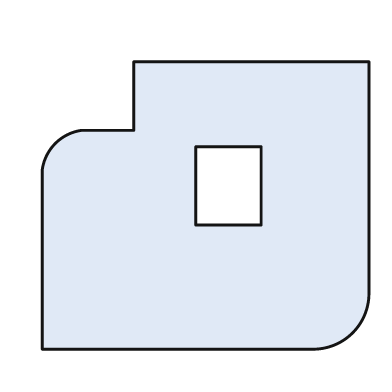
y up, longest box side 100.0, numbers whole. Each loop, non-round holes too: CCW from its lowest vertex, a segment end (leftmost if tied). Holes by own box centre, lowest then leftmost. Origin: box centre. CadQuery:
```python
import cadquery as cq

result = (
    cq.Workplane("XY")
    .moveTo(-50.0, -44.0)
    .lineTo(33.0, -44.0)
    .threePointArc((45.0, -39.0), (50.0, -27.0))
    .lineTo(50.0, 44.0)
    .lineTo(-22.0, 44.0)
    .lineTo(-22.0, 23.0)
    .lineTo(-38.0, 23.0)
    .threePointArc((-46.0, 19.0), (-50.0, 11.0))
    .close()
    .moveTo(-3.0, -6.0)
    .lineTo(17.0, -6.0)
    .lineTo(17.0, 18.0)
    .lineTo(-3.0, 18.0)
    .close()
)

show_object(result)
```